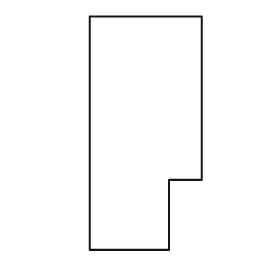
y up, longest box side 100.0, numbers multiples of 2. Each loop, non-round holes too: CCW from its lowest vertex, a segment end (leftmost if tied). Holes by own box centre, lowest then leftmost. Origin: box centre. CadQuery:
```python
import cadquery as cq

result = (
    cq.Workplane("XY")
    .moveTo(-24.0, -50.0)
    .lineTo(10.0, -50.0)
    .lineTo(10.0, -20.0)
    .lineTo(24.0, -20.0)
    .lineTo(24.0, 50.0)
    .lineTo(-24.0, 50.0)
    .close()
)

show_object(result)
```